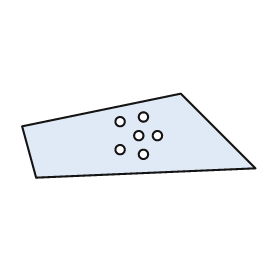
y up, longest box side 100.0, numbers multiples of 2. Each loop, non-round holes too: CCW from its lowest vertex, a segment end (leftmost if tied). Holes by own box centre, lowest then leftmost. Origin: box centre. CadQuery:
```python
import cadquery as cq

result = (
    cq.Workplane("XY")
    .moveTo(-44.0, -18.0)
    .lineTo(50.0, -14.0)
    .lineTo(18.0, 18.0)
    .lineTo(-50.0, 4.0)
    .close()
    .moveTo(2.0, -8.0)
    .circle(2.0)
    .moveTo(-8.0, -6.0)
    .circle(2.0)
    .moveTo(0.0, 0.0)
    .circle(2.0)
    .moveTo(8.0, 0.0)
    .circle(2.0)
    .moveTo(-8.0, 6.0)
    .circle(2.0)
    .moveTo(2.0, 8.0)
    .circle(2.0)
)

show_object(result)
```